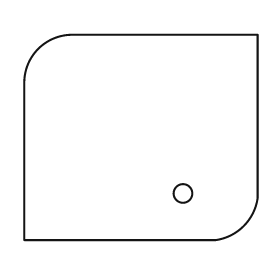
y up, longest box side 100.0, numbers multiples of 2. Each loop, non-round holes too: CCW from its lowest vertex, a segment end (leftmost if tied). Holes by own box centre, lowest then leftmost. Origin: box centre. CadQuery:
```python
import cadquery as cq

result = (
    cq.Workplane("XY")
    .moveTo(-50.0, -44.0)
    .lineTo(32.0, -44.0)
    .threePointArc((44.0, -38.0), (50.0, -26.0))
    .lineTo(50.0, 44.0)
    .lineTo(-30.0, 44.0)
    .threePointArc((-44.0, 38.0), (-50.0, 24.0))
    .close()
    .moveTo(18.0, -24.0)
    .circle(4.0)
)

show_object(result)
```